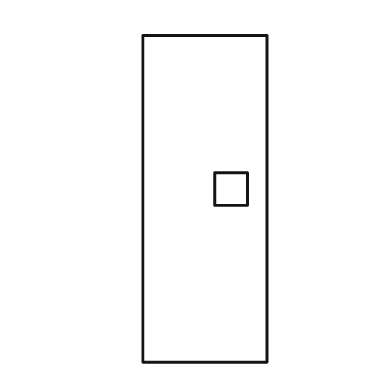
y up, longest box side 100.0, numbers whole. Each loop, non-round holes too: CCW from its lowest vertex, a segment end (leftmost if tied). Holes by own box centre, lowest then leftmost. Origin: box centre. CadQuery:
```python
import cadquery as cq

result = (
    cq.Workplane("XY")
    .moveTo(-19.0, -50.0)
    .lineTo(19.0, -50.0)
    .lineTo(19.0, 50.0)
    .lineTo(-19.0, 50.0)
    .close()
    .moveTo(3.0, -2.0)
    .lineTo(13.0, -2.0)
    .lineTo(13.0, 8.0)
    .lineTo(3.0, 8.0)
    .close()
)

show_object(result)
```